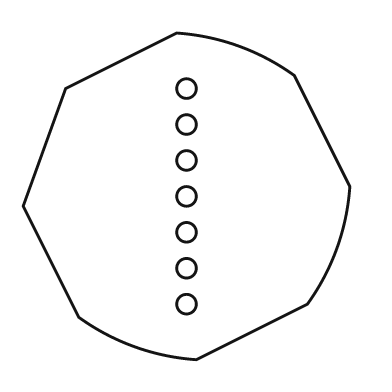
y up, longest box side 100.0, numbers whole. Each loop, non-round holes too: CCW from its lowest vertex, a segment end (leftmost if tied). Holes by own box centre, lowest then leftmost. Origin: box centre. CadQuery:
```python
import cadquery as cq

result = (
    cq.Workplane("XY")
    .moveTo(3.0, -50.0)
    .lineTo(37.0, -33.0)
    .threePointArc((46.0, -16.0), (50.0, 3.0))
    .lineTo(33.0, 37.0)
    .threePointArc((16.0, 46.0), (-3.0, 50.0))
    .lineTo(-37.0, 33.0)
    .lineTo(-50.0, -3.0)
    .lineTo(-33.0, -37.0)
    .threePointArc((-16.0, -46.0), (3.0, -50.0))
    .close()
    .moveTo(0.0, -33.0)
    .circle(3.0)
    .moveTo(0.0, -22.0)
    .circle(3.0)
    .moveTo(0.0, -11.0)
    .circle(3.0)
    .moveTo(0.0, 0.0)
    .circle(3.0)
    .moveTo(0.0, 11.0)
    .circle(3.0)
    .moveTo(0.0, 22.0)
    .circle(3.0)
    .moveTo(0.0, 33.0)
    .circle(3.0)
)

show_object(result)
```